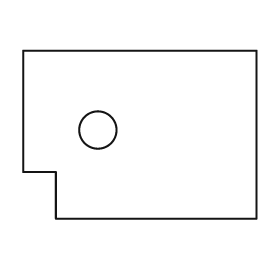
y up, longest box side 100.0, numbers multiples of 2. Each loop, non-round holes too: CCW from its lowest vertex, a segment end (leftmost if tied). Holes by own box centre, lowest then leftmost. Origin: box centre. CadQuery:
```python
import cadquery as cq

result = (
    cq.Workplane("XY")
    .moveTo(-36.0, -36.0)
    .lineTo(50.0, -36.0)
    .lineTo(50.0, 36.0)
    .lineTo(-50.0, 36.0)
    .lineTo(-50.0, -16.0)
    .lineTo(-36.0, -16.0)
    .close()
    .moveTo(-18.0, 2.0)
    .circle(8.0)
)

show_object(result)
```